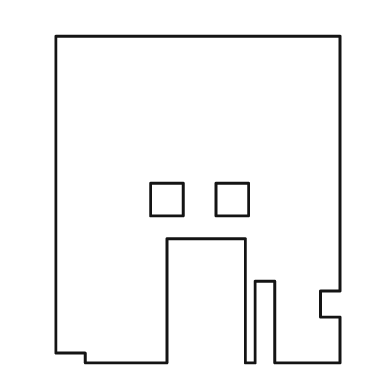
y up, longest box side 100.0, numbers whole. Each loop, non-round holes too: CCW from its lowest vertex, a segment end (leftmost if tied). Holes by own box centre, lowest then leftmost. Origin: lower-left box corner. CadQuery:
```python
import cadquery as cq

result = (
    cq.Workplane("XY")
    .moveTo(9.0, 0.0)
    .lineTo(34.0, 0.0)
    .lineTo(34.0, 38.0)
    .lineTo(58.0, 38.0)
    .lineTo(58.0, 0.0)
    .lineTo(61.0, 0.0)
    .lineTo(61.0, 25.0)
    .lineTo(67.0, 25.0)
    .lineTo(67.0, 0.0)
    .lineTo(87.0, 0.0)
    .lineTo(87.0, 14.0)
    .lineTo(81.0, 14.0)
    .lineTo(81.0, 22.0)
    .lineTo(87.0, 22.0)
    .lineTo(87.0, 100.0)
    .lineTo(0.0, 100.0)
    .lineTo(0.0, 3.0)
    .lineTo(9.0, 3.0)
    .close()
    .moveTo(29.0, 45.0)
    .lineTo(39.0, 45.0)
    .lineTo(39.0, 55.0)
    .lineTo(29.0, 55.0)
    .close()
    .moveTo(49.0, 45.0)
    .lineTo(59.0, 45.0)
    .lineTo(59.0, 55.0)
    .lineTo(49.0, 55.0)
    .close()
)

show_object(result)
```